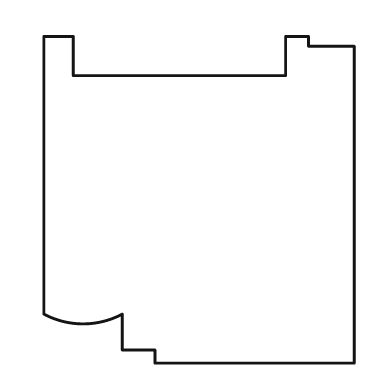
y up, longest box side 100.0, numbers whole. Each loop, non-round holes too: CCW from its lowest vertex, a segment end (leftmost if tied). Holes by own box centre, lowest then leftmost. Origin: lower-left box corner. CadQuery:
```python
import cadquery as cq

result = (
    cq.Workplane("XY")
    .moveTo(34.0, 0.0)
    .lineTo(95.0, 0.0)
    .lineTo(95.0, 97.0)
    .lineTo(81.0, 97.0)
    .lineTo(81.0, 100.0)
    .lineTo(74.0, 100.0)
    .lineTo(74.0, 88.0)
    .lineTo(9.0, 88.0)
    .lineTo(9.0, 100.0)
    .lineTo(0.0, 100.0)
    .lineTo(0.0, 15.0)
    .threePointArc((12.0, 12.0), (24.0, 15.0))
    .lineTo(24.0, 4.0)
    .lineTo(34.0, 4.0)
    .close()
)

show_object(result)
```